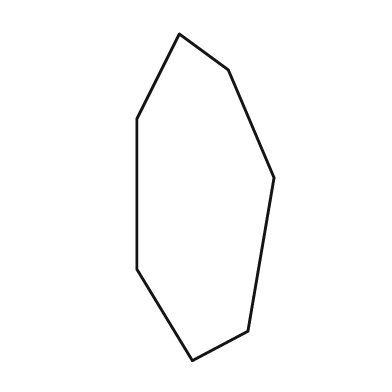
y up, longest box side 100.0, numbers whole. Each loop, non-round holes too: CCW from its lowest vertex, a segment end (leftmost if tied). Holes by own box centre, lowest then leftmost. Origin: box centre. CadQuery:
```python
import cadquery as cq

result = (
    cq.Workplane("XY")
    .moveTo(-4.0, -50.0)
    .lineTo(13.0, -41.0)
    .lineTo(21.0, 6.0)
    .lineTo(7.0, 39.0)
    .lineTo(-8.0, 50.0)
    .lineTo(-21.0, 24.0)
    .lineTo(-21.0, -22.0)
    .close()
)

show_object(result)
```